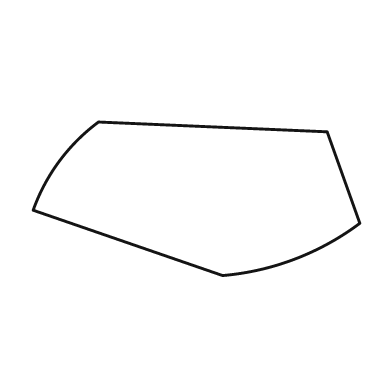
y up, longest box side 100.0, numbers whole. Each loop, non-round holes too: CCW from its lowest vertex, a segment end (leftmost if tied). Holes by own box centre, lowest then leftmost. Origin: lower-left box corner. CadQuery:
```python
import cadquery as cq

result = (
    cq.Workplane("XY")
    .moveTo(58.0, 0.0)
    .threePointArc((80.0, 5.0), (100.0, 16.0))
    .lineTo(90.0, 44.0)
    .lineTo(20.0, 47.0)
    .threePointArc((8.0, 35.0), (0.0, 20.0))
    .close()
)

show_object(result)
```